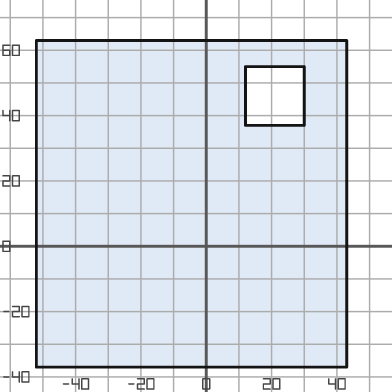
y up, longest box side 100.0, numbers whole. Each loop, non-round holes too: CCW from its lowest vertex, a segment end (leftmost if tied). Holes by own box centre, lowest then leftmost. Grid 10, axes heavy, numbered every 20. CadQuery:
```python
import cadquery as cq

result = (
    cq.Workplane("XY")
    .moveTo(-52.0, -37.0)
    .lineTo(43.0, -37.0)
    .lineTo(43.0, 63.0)
    .lineTo(-52.0, 63.0)
    .close()
    .moveTo(12.0, 37.0)
    .lineTo(30.0, 37.0)
    .lineTo(30.0, 55.0)
    .lineTo(12.0, 55.0)
    .close()
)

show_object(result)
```